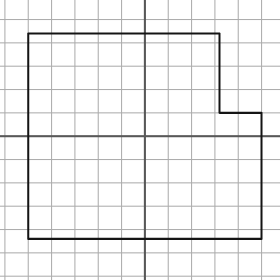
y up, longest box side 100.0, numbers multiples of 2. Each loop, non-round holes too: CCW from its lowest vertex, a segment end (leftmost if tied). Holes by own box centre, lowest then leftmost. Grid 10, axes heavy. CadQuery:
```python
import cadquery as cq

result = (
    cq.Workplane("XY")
    .moveTo(-50.0, -44.0)
    .lineTo(50.0, -44.0)
    .lineTo(50.0, 10.0)
    .lineTo(32.0, 10.0)
    .lineTo(32.0, 44.0)
    .lineTo(-50.0, 44.0)
    .close()
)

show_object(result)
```